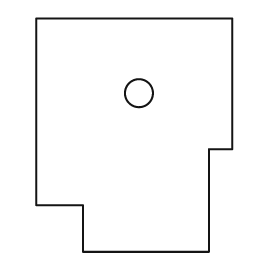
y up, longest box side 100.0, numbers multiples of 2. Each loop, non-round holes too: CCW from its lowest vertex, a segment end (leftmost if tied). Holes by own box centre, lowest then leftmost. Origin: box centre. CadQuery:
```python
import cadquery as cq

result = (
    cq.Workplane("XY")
    .moveTo(-22.0, -50.0)
    .lineTo(32.0, -50.0)
    .lineTo(32.0, -6.0)
    .lineTo(42.0, -6.0)
    .lineTo(42.0, 50.0)
    .lineTo(-42.0, 50.0)
    .lineTo(-42.0, -30.0)
    .lineTo(-22.0, -30.0)
    .close()
    .moveTo(2.0, 18.0)
    .circle(6.0)
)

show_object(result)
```